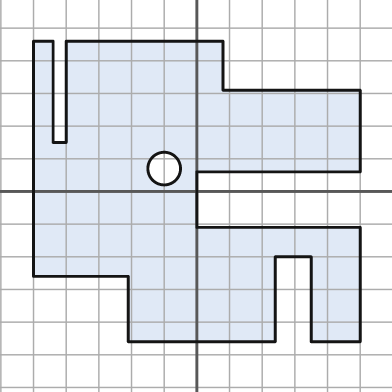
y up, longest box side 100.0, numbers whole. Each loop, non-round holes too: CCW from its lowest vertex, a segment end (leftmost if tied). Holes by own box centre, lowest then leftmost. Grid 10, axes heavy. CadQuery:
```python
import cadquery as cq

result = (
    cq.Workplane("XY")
    .moveTo(-21.0, -46.0)
    .lineTo(24.0, -46.0)
    .lineTo(24.0, -20.0)
    .lineTo(35.0, -20.0)
    .lineTo(35.0, -46.0)
    .lineTo(50.0, -46.0)
    .lineTo(50.0, -11.0)
    .lineTo(0.0, -11.0)
    .lineTo(0.0, 6.0)
    .lineTo(50.0, 6.0)
    .lineTo(50.0, 31.0)
    .lineTo(8.0, 31.0)
    .lineTo(8.0, 46.0)
    .lineTo(-40.0, 46.0)
    .lineTo(-40.0, 15.0)
    .lineTo(-44.0, 15.0)
    .lineTo(-44.0, 46.0)
    .lineTo(-50.0, 46.0)
    .lineTo(-50.0, -26.0)
    .lineTo(-21.0, -26.0)
    .close()
    .moveTo(-10.0, 7.0)
    .circle(5.0)
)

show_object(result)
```